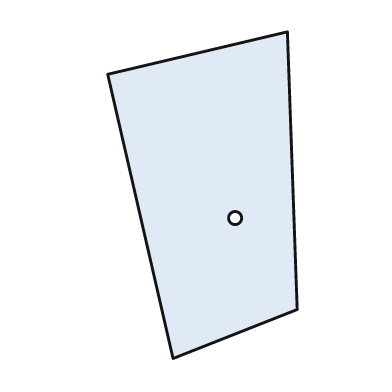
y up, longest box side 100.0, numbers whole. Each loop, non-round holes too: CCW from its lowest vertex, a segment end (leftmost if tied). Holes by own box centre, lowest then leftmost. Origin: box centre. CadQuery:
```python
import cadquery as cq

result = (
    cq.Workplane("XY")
    .moveTo(-9.0, -50.0)
    .lineTo(29.0, -35.0)
    .lineTo(26.0, 50.0)
    .lineTo(-29.0, 37.0)
    .close()
    .moveTo(10.0, -7.0)
    .circle(2.0)
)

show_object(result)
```